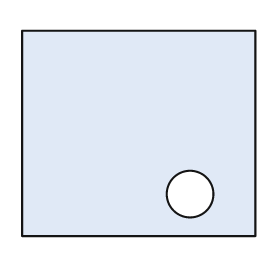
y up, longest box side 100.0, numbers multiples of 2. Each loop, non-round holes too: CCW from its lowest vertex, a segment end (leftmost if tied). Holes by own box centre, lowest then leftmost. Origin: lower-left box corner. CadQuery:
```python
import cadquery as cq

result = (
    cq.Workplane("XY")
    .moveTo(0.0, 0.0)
    .lineTo(100.0, 0.0)
    .lineTo(100.0, 88.0)
    .lineTo(0.0, 88.0)
    .close()
    .moveTo(72.0, 18.0)
    .circle(10.0)
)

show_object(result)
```